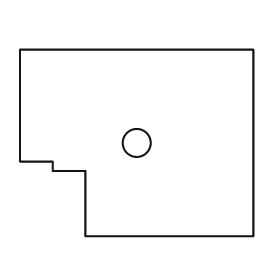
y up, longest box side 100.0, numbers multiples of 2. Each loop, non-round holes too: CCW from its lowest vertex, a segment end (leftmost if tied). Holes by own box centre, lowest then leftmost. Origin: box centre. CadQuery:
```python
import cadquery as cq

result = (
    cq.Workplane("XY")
    .moveTo(-22.0, -40.0)
    .lineTo(50.0, -40.0)
    .lineTo(50.0, 40.0)
    .lineTo(-50.0, 40.0)
    .lineTo(-50.0, -8.0)
    .lineTo(-36.0, -8.0)
    .lineTo(-36.0, -12.0)
    .lineTo(-22.0, -12.0)
    .close()
    .moveTo(0.0, 0.0)
    .circle(6.0)
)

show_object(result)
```